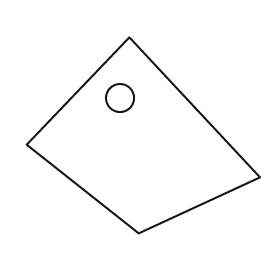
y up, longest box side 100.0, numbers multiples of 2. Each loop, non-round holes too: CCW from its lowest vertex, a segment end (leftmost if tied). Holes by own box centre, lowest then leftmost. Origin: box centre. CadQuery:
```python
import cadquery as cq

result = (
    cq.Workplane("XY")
    .moveTo(-2.0, -42.0)
    .lineTo(50.0, -18.0)
    .lineTo(-6.0, 42.0)
    .lineTo(-50.0, -4.0)
    .close()
    .moveTo(-10.0, 16.0)
    .circle(6.0)
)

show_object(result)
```